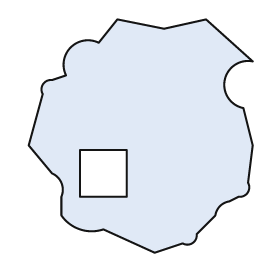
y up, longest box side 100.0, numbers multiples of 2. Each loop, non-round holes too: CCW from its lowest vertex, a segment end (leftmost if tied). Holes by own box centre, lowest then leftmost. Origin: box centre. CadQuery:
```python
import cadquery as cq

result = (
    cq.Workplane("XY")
    .moveTo(6.0, -50.0)
    .lineTo(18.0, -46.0)
    .threePointArc((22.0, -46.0), (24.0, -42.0))
    .lineTo(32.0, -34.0)
    .threePointArc((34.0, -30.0), (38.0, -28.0))
    .lineTo(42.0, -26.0)
    .threePointArc((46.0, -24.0), (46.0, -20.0))
    .lineTo(48.0, -4.0)
    .lineTo(44.0, 12.0)
    .threePointArc((36.0, 24.0), (48.0, 32.0))
    .lineTo(28.0, 50.0)
    .lineTo(10.0, 46.0)
    .lineTo(-10.0, 50.0)
    .lineTo(-18.0, 40.0)
    .threePointArc((-30.0, 38.0), (-32.0, 26.0))
    .lineTo(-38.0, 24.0)
    .threePointArc((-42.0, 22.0), (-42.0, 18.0))
    .lineTo(-48.0, -4.0)
    .lineTo(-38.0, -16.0)
    .threePointArc((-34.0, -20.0), (-34.0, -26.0))
    .lineTo(-34.0, -34.0)
    .threePointArc((-26.0, -40.0), (-16.0, -40.0))
    .close()
    .moveTo(-26.0, -26.0)
    .lineTo(-6.0, -26.0)
    .lineTo(-6.0, -6.0)
    .lineTo(-26.0, -6.0)
    .close()
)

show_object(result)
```